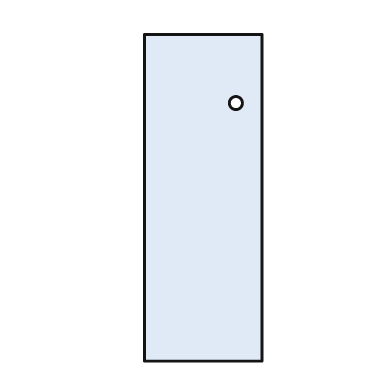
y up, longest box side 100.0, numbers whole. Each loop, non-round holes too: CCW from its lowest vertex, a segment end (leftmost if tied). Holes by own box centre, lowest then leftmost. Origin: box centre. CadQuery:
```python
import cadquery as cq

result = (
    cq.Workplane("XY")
    .moveTo(-18.0, -50.0)
    .lineTo(18.0, -50.0)
    .lineTo(18.0, 50.0)
    .lineTo(-18.0, 50.0)
    .close()
    .moveTo(10.0, 29.0)
    .circle(2.0)
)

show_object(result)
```